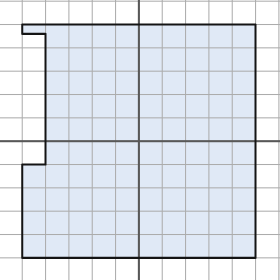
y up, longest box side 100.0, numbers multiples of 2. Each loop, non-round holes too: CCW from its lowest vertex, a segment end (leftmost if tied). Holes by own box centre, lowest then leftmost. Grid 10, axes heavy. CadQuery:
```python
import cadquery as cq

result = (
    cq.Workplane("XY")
    .moveTo(-50.0, -50.0)
    .lineTo(50.0, -50.0)
    .lineTo(50.0, 50.0)
    .lineTo(-50.0, 50.0)
    .lineTo(-50.0, 46.0)
    .lineTo(-40.0, 46.0)
    .lineTo(-40.0, -10.0)
    .lineTo(-50.0, -10.0)
    .close()
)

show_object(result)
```